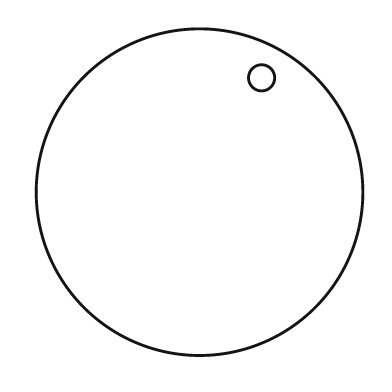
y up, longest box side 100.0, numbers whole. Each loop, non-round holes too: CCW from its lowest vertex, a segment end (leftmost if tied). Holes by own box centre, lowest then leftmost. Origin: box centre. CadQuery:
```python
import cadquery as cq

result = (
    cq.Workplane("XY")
    .moveTo(0.0, 0.0)
    .circle(50.0)
    .moveTo(19.0, 35.0)
    .circle(4.0)
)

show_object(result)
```